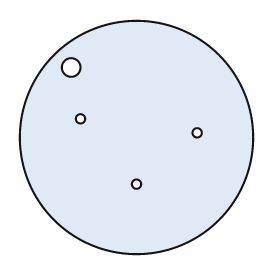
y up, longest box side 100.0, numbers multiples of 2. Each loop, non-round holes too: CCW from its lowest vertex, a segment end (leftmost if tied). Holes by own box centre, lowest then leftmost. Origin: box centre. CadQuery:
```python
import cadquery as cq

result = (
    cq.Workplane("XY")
    .moveTo(0.0, 0.0)
    .circle(50.0)
    .moveTo(0.0, -20.0)
    .circle(2.0)
    .moveTo(26.0, 2.0)
    .circle(2.0)
    .moveTo(-24.0, 8.0)
    .circle(2.0)
    .moveTo(-28.0, 30.0)
    .circle(4.0)
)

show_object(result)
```